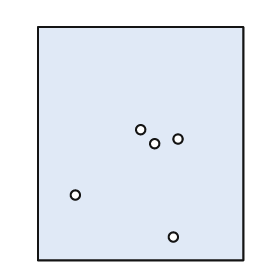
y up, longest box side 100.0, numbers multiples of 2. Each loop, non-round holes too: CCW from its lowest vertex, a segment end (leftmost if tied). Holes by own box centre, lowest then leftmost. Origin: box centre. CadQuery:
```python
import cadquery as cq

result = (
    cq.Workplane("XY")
    .moveTo(-44.0, -50.0)
    .lineTo(44.0, -50.0)
    .lineTo(44.0, 50.0)
    .lineTo(-44.0, 50.0)
    .close()
    .moveTo(14.0, -40.0)
    .circle(2.0)
    .moveTo(-28.0, -22.0)
    .circle(2.0)
    .moveTo(6.0, 0.0)
    .circle(2.0)
    .moveTo(16.0, 2.0)
    .circle(2.0)
    .moveTo(0.0, 6.0)
    .circle(2.0)
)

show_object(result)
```